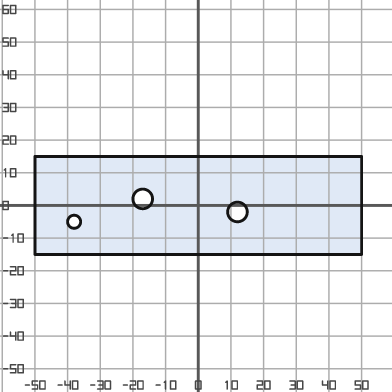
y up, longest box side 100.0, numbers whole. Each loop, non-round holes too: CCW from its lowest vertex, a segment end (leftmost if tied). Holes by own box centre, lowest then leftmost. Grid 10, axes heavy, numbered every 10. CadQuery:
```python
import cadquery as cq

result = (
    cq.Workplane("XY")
    .moveTo(-50.0, -15.0)
    .lineTo(50.0, -15.0)
    .lineTo(50.0, 15.0)
    .lineTo(-50.0, 15.0)
    .close()
    .moveTo(-38.0, -5.0)
    .circle(2.0)
    .moveTo(12.0, -2.0)
    .circle(3.0)
    .moveTo(-17.0, 2.0)
    .circle(3.0)
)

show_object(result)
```